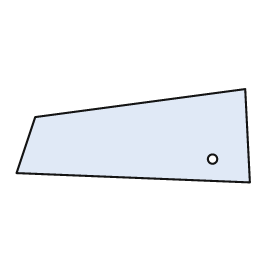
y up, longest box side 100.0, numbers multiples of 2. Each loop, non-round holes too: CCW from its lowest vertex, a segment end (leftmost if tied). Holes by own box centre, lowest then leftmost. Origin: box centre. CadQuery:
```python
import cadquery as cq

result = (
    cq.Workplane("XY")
    .moveTo(50.0, -20.0)
    .lineTo(48.0, 20.0)
    .lineTo(-42.0, 8.0)
    .lineTo(-50.0, -16.0)
    .close()
    .moveTo(34.0, -10.0)
    .circle(2.0)
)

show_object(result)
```